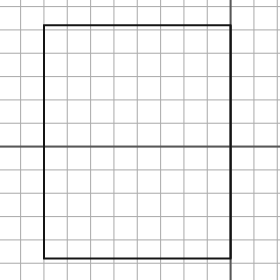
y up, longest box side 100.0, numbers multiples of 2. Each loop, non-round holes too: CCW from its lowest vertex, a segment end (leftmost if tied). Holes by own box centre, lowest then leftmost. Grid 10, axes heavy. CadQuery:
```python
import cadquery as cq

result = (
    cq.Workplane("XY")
    .moveTo(-80.0, -48.0)
    .lineTo(0.0, -48.0)
    .lineTo(0.0, 52.0)
    .lineTo(-80.0, 52.0)
    .close()
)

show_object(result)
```